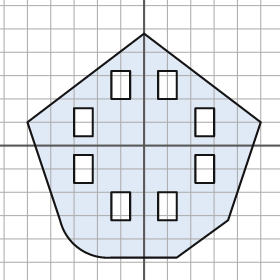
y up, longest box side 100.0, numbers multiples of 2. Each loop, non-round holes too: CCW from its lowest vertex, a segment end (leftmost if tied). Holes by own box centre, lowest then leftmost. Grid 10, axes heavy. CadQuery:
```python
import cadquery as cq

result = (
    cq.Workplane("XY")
    .moveTo(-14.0, -48.0)
    .lineTo(14.0, -48.0)
    .lineTo(36.0, -32.0)
    .lineTo(50.0, 10.0)
    .lineTo(0.0, 48.0)
    .lineTo(-50.0, 10.0)
    .lineTo(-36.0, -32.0)
    .threePointArc((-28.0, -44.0), (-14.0, -48.0))
    .close()
    .moveTo(-14.0, -32.0)
    .lineTo(-6.0, -32.0)
    .lineTo(-6.0, -20.0)
    .lineTo(-14.0, -20.0)
    .close()
    .moveTo(6.0, -32.0)
    .lineTo(14.0, -32.0)
    .lineTo(14.0, -20.0)
    .lineTo(6.0, -20.0)
    .close()
    .moveTo(-30.0, -16.0)
    .lineTo(-22.0, -16.0)
    .lineTo(-22.0, -4.0)
    .lineTo(-30.0, -4.0)
    .close()
    .moveTo(22.0, -16.0)
    .lineTo(30.0, -16.0)
    .lineTo(30.0, -4.0)
    .lineTo(22.0, -4.0)
    .close()
    .moveTo(-30.0, 4.0)
    .lineTo(-22.0, 4.0)
    .lineTo(-22.0, 16.0)
    .lineTo(-30.0, 16.0)
    .close()
    .moveTo(22.0, 4.0)
    .lineTo(30.0, 4.0)
    .lineTo(30.0, 16.0)
    .lineTo(22.0, 16.0)
    .close()
    .moveTo(-14.0, 20.0)
    .lineTo(-6.0, 20.0)
    .lineTo(-6.0, 32.0)
    .lineTo(-14.0, 32.0)
    .close()
    .moveTo(6.0, 20.0)
    .lineTo(14.0, 20.0)
    .lineTo(14.0, 32.0)
    .lineTo(6.0, 32.0)
    .close()
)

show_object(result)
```